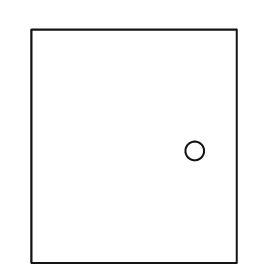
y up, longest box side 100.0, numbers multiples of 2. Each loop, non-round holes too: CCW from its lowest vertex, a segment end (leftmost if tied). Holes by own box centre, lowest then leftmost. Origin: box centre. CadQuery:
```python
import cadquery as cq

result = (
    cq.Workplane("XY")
    .moveTo(-44.0, -50.0)
    .lineTo(44.0, -50.0)
    .lineTo(44.0, 50.0)
    .lineTo(-44.0, 50.0)
    .close()
    .moveTo(26.0, -2.0)
    .circle(4.0)
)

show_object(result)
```